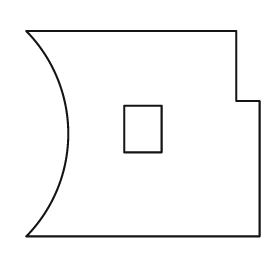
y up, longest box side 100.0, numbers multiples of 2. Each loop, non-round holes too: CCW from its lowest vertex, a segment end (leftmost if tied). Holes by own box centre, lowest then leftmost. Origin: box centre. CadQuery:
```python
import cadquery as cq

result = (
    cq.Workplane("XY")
    .moveTo(-50.0, -44.0)
    .lineTo(50.0, -44.0)
    .lineTo(50.0, 14.0)
    .lineTo(40.0, 14.0)
    .lineTo(40.0, 44.0)
    .lineTo(-50.0, 44.0)
    .threePointArc((-32.0, 0.0), (-50.0, -44.0))
    .close()
    .moveTo(-8.0, -8.0)
    .lineTo(8.0, -8.0)
    .lineTo(8.0, 12.0)
    .lineTo(-8.0, 12.0)
    .close()
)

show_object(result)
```